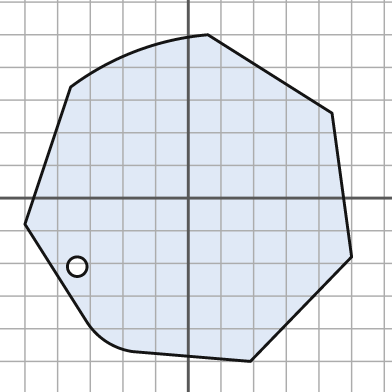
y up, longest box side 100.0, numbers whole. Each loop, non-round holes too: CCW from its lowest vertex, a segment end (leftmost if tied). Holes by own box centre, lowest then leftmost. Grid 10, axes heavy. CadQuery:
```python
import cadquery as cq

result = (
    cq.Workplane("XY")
    .moveTo(19.0, -50.0)
    .lineTo(50.0, -18.0)
    .lineTo(44.0, 26.0)
    .lineTo(6.0, 50.0)
    .threePointArc((-16.0, 45.0), (-36.0, 34.0))
    .lineTo(-50.0, -8.0)
    .lineTo(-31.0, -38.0)
    .threePointArc((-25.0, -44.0), (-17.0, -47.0))
    .close()
    .moveTo(-34.0, -21.0)
    .circle(3.0)
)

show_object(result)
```